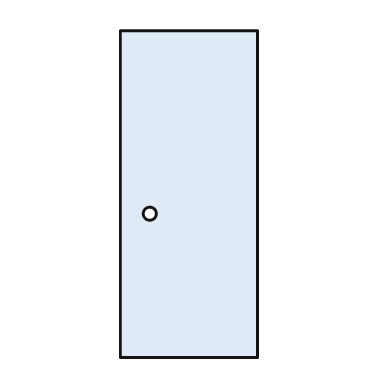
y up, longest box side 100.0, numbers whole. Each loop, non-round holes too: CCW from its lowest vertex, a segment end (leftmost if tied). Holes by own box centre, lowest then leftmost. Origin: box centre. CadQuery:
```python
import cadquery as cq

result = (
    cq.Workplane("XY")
    .moveTo(-21.0, -50.0)
    .lineTo(21.0, -50.0)
    .lineTo(21.0, 50.0)
    .lineTo(-21.0, 50.0)
    .close()
    .moveTo(-12.0, -6.0)
    .circle(2.0)
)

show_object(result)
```